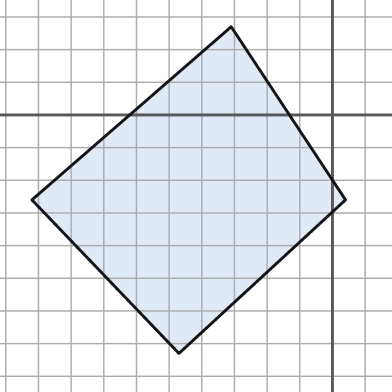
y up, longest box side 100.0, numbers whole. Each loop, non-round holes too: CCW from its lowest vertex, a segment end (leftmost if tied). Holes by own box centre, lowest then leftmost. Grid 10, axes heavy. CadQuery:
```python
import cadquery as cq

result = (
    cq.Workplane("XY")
    .moveTo(-47.0, -73.0)
    .lineTo(4.0, -26.0)
    .lineTo(-31.0, 27.0)
    .lineTo(-92.0, -26.0)
    .close()
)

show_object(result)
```